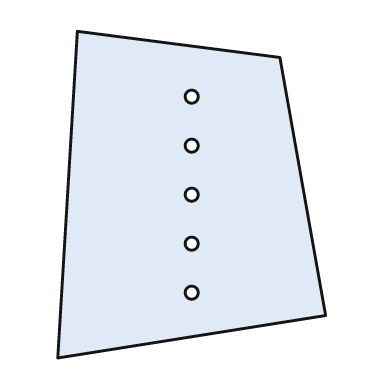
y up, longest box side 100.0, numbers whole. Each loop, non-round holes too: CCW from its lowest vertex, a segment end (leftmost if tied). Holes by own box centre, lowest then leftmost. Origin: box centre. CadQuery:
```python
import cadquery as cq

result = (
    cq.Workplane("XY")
    .moveTo(-41.0, -50.0)
    .lineTo(41.0, -37.0)
    .lineTo(27.0, 42.0)
    .lineTo(-35.0, 50.0)
    .close()
    .moveTo(0.0, -30.0)
    .circle(2.0)
    .moveTo(0.0, -15.0)
    .circle(2.0)
    .moveTo(0.0, 0.0)
    .circle(2.0)
    .moveTo(0.0, 15.0)
    .circle(2.0)
    .moveTo(0.0, 30.0)
    .circle(2.0)
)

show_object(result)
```